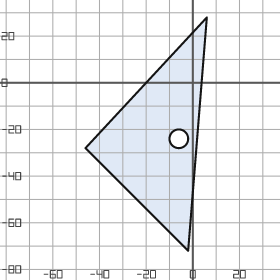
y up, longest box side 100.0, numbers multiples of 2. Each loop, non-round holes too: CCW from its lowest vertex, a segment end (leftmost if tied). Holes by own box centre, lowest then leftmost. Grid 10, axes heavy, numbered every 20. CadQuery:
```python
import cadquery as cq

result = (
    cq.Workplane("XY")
    .moveTo(-2.0, -72.0)
    .lineTo(6.0, 28.0)
    .lineTo(-46.0, -28.0)
    .close()
    .moveTo(-6.0, -24.0)
    .circle(4.0)
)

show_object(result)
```